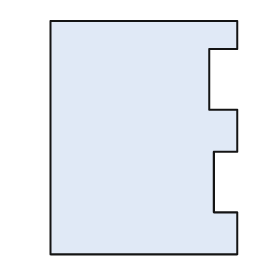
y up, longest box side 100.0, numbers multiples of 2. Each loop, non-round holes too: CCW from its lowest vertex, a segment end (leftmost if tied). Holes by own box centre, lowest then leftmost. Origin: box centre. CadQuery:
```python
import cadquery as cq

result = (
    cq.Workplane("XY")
    .moveTo(-40.0, -50.0)
    .lineTo(40.0, -50.0)
    .lineTo(40.0, -32.0)
    .lineTo(30.0, -32.0)
    .lineTo(30.0, -6.0)
    .lineTo(40.0, -6.0)
    .lineTo(40.0, 12.0)
    .lineTo(28.0, 12.0)
    .lineTo(28.0, 38.0)
    .lineTo(40.0, 38.0)
    .lineTo(40.0, 50.0)
    .lineTo(-40.0, 50.0)
    .close()
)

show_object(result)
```